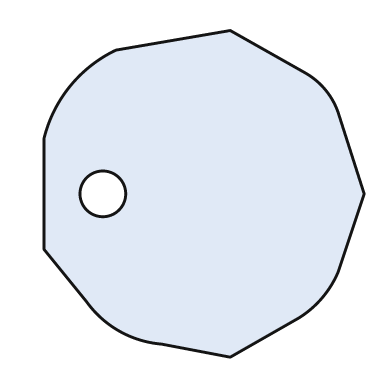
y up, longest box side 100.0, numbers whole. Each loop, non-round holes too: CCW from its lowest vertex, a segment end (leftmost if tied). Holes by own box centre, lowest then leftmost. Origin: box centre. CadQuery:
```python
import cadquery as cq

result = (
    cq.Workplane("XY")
    .moveTo(8.0, -50.0)
    .lineTo(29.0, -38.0)
    .threePointArc((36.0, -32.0), (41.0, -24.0))
    .lineTo(49.0, 0.0)
    .lineTo(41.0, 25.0)
    .threePointArc((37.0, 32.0), (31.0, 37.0))
    .lineTo(8.0, 50.0)
    .lineTo(-27.0, 44.0)
    .threePointArc((-41.0, 33.0), (-49.0, 17.0))
    .lineTo(-49.0, -17.0)
    .lineTo(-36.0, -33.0)
    .threePointArc((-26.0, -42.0), (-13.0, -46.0))
    .close()
    .moveTo(-31.0, 0.0)
    .circle(7.0)
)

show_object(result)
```